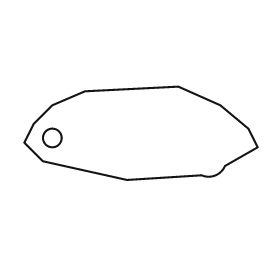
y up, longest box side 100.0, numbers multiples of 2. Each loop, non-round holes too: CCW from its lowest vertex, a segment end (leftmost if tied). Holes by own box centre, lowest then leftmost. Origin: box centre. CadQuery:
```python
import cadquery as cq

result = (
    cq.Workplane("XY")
    .moveTo(-6.0, -20.0)
    .lineTo(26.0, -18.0)
    .threePointArc((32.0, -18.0), (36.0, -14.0))
    .lineTo(50.0, -6.0)
    .lineTo(46.0, 2.0)
    .lineTo(34.0, 12.0)
    .lineTo(16.0, 20.0)
    .lineTo(-24.0, 18.0)
    .lineTo(-38.0, 12.0)
    .lineTo(-46.0, 4.0)
    .lineTo(-50.0, -4.0)
    .lineTo(-42.0, -12.0)
    .close()
    .moveTo(-38.0, -2.0)
    .circle(4.0)
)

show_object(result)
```